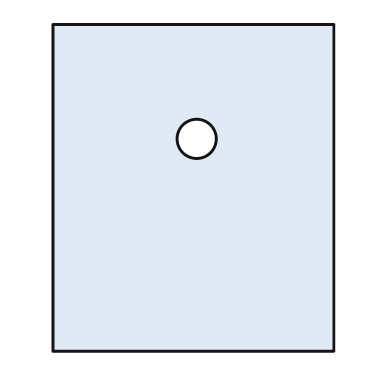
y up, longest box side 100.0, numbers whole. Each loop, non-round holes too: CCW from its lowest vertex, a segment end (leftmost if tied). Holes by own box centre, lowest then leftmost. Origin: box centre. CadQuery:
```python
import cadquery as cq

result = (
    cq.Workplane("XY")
    .moveTo(-43.0, -50.0)
    .lineTo(43.0, -50.0)
    .lineTo(43.0, 50.0)
    .lineTo(-43.0, 50.0)
    .close()
    .moveTo(1.0, 15.0)
    .circle(6.0)
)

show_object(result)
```